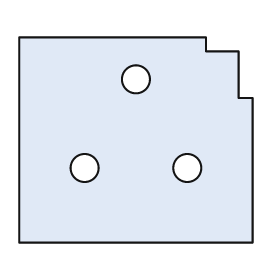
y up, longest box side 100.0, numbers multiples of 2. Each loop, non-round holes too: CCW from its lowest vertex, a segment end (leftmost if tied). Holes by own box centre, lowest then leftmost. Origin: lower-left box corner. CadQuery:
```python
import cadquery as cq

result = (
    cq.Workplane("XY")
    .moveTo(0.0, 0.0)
    .lineTo(100.0, 0.0)
    .lineTo(100.0, 62.0)
    .lineTo(94.0, 62.0)
    .lineTo(94.0, 82.0)
    .lineTo(80.0, 82.0)
    .lineTo(80.0, 88.0)
    .lineTo(0.0, 88.0)
    .close()
    .moveTo(28.0, 32.0)
    .circle(6.0)
    .moveTo(72.0, 32.0)
    .circle(6.0)
    .moveTo(50.0, 70.0)
    .circle(6.0)
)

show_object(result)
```